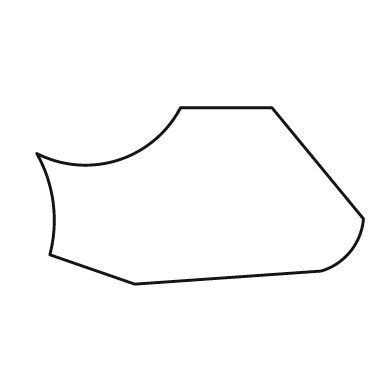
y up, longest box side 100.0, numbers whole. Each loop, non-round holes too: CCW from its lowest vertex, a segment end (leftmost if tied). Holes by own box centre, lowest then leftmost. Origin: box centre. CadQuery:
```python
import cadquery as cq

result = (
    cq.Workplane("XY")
    .moveTo(-20.0, -27.0)
    .lineTo(37.0, -23.0)
    .threePointArc((46.0, -17.0), (50.0, -7.0))
    .lineTo(22.0, 27.0)
    .lineTo(-6.0, 27.0)
    .threePointArc((-25.0, 11.0), (-50.0, 13.0))
    .threePointArc((-45.0, -2.0), (-46.0, -18.0))
    .close()
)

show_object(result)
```